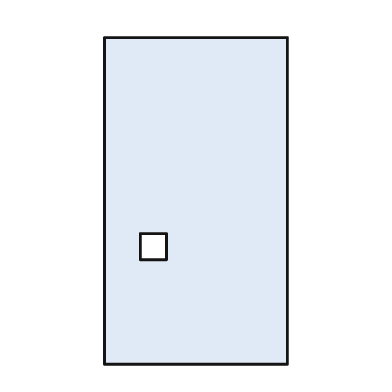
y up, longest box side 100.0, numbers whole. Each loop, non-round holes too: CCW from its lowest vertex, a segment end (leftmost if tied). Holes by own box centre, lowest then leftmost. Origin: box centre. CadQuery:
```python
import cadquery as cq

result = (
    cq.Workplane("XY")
    .moveTo(-28.0, -50.0)
    .lineTo(28.0, -50.0)
    .lineTo(28.0, 50.0)
    .lineTo(-28.0, 50.0)
    .close()
    .moveTo(-17.0, -18.0)
    .lineTo(-9.0, -18.0)
    .lineTo(-9.0, -10.0)
    .lineTo(-17.0, -10.0)
    .close()
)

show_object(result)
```